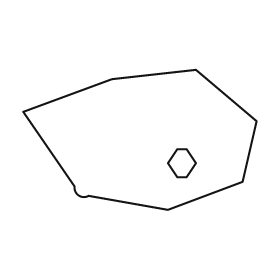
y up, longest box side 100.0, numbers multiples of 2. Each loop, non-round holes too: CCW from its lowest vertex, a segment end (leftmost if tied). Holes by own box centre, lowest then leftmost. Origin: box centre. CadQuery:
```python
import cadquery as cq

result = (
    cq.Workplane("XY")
    .moveTo(12.0, -30.0)
    .lineTo(44.0, -18.0)
    .lineTo(50.0, 8.0)
    .lineTo(24.0, 30.0)
    .lineTo(-12.0, 26.0)
    .lineTo(-50.0, 12.0)
    .lineTo(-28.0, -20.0)
    .threePointArc((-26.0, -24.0), (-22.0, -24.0))
    .close()
    .moveTo(16.0, -16.0)
    .lineTo(20.0, -16.0)
    .lineTo(24.0, -10.0)
    .lineTo(20.0, -4.0)
    .lineTo(16.0, -4.0)
    .lineTo(12.0, -10.0)
    .close()
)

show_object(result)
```